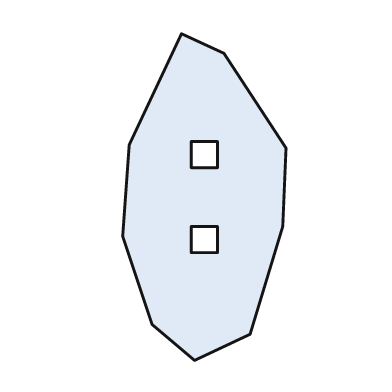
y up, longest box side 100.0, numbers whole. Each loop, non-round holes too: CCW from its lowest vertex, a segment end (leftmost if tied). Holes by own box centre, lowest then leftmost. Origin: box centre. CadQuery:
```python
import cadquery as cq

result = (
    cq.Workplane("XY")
    .moveTo(-3.0, -50.0)
    .lineTo(14.0, -42.0)
    .lineTo(24.0, -9.0)
    .lineTo(25.0, 15.0)
    .lineTo(6.0, 44.0)
    .lineTo(-7.0, 50.0)
    .lineTo(-23.0, 16.0)
    .lineTo(-25.0, -12.0)
    .lineTo(-16.0, -39.0)
    .close()
    .moveTo(-4.0, -17.0)
    .lineTo(4.0, -17.0)
    .lineTo(4.0, -9.0)
    .lineTo(-4.0, -9.0)
    .close()
    .moveTo(-4.0, 9.0)
    .lineTo(4.0, 9.0)
    .lineTo(4.0, 17.0)
    .lineTo(-4.0, 17.0)
    .close()
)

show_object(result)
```